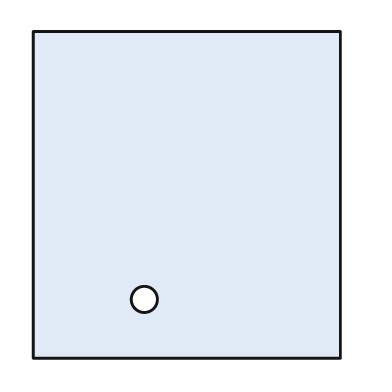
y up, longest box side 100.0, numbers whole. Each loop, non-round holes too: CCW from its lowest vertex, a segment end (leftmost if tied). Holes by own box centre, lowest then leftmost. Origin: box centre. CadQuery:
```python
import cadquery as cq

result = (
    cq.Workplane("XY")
    .moveTo(-47.0, -50.0)
    .lineTo(47.0, -50.0)
    .lineTo(47.0, 50.0)
    .lineTo(-47.0, 50.0)
    .close()
    .moveTo(-13.0, -32.0)
    .circle(4.0)
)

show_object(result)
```